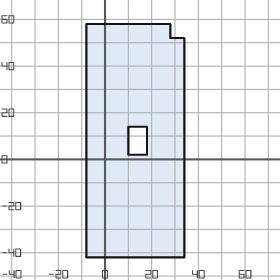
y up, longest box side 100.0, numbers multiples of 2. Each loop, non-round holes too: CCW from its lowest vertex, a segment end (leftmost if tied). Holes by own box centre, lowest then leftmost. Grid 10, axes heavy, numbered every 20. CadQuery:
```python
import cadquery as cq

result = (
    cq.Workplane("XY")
    .moveTo(-8.0, -42.0)
    .lineTo(34.0, -42.0)
    .lineTo(34.0, 52.0)
    .lineTo(28.0, 52.0)
    .lineTo(28.0, 58.0)
    .lineTo(-8.0, 58.0)
    .close()
    .moveTo(10.0, 2.0)
    .lineTo(18.0, 2.0)
    .lineTo(18.0, 14.0)
    .lineTo(10.0, 14.0)
    .close()
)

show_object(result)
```